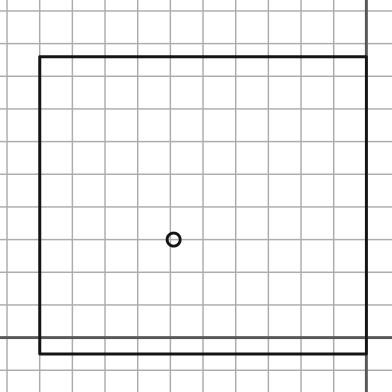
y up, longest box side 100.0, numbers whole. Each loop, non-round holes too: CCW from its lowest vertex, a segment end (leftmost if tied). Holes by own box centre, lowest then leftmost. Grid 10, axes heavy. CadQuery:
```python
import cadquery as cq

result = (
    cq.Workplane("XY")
    .moveTo(-100.0, -5.0)
    .lineTo(0.0, -5.0)
    .lineTo(0.0, 86.0)
    .lineTo(-100.0, 86.0)
    .close()
    .moveTo(-59.0, 30.0)
    .circle(2.0)
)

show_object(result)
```